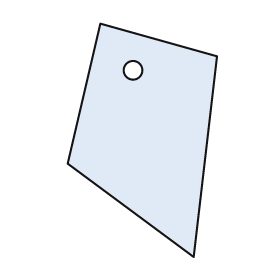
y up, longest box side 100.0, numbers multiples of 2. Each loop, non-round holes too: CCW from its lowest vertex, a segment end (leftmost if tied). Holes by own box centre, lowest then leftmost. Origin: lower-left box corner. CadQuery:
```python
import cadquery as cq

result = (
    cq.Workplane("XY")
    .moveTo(54.0, 0.0)
    .lineTo(64.0, 86.0)
    .lineTo(14.0, 100.0)
    .lineTo(0.0, 40.0)
    .close()
    .moveTo(28.0, 80.0)
    .circle(4.0)
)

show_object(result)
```